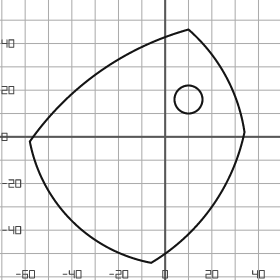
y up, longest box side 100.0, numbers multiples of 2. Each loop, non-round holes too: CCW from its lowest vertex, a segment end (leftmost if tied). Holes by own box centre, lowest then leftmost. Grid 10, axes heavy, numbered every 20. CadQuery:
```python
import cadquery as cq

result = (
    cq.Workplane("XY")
    .moveTo(-6.0, -54.0)
    .threePointArc((20.0, -30.0), (34.0, 2.0))
    .threePointArc((26.0, 26.0), (10.0, 46.0))
    .threePointArc((-28.0, 28.0), (-58.0, -2.0))
    .threePointArc((-40.0, -36.0), (-6.0, -54.0))
    .close()
    .moveTo(10.0, 16.0)
    .circle(6.0)
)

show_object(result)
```